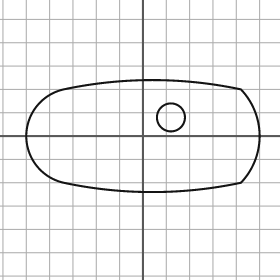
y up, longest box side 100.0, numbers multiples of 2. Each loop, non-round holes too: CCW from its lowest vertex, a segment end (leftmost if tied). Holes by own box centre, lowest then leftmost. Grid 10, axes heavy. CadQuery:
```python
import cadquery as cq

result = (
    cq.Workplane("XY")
    .moveTo(-34.0, -20.0)
    .threePointArc((4.0, -24.0), (42.0, -20.0))
    .threePointArc((50.0, 0.0), (42.0, 20.0))
    .threePointArc((4.0, 24.0), (-34.0, 20.0))
    .threePointArc((-50.0, 0.0), (-34.0, -20.0))
    .close()
    .moveTo(12.0, 8.0)
    .circle(6.0)
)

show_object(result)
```